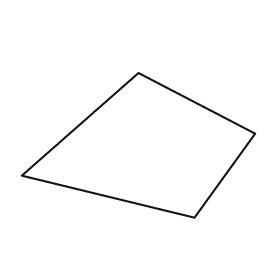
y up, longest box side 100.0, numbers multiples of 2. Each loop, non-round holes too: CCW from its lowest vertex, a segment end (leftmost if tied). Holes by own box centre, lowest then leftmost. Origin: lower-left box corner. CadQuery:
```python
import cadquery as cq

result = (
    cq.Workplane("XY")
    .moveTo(74.0, 0.0)
    .lineTo(100.0, 36.0)
    .lineTo(50.0, 62.0)
    .lineTo(0.0, 18.0)
    .close()
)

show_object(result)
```